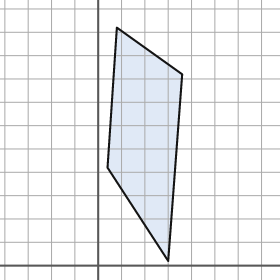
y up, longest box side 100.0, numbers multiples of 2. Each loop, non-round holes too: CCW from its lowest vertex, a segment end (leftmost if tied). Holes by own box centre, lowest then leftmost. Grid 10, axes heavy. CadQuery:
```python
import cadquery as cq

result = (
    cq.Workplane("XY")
    .moveTo(30.0, 2.0)
    .lineTo(36.0, 82.0)
    .lineTo(8.0, 102.0)
    .lineTo(4.0, 42.0)
    .close()
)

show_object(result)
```